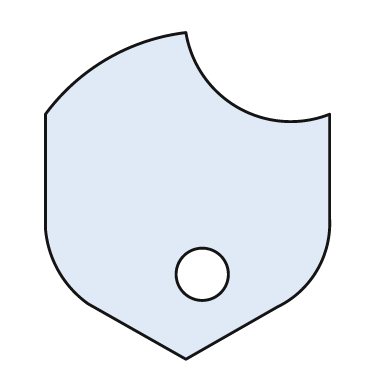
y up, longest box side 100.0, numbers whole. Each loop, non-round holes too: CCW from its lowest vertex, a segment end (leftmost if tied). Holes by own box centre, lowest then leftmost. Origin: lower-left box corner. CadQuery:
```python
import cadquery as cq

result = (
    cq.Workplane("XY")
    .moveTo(43.0, 0.0)
    .lineTo(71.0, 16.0)
    .threePointArc((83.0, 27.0), (87.0, 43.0))
    .lineTo(87.0, 75.0)
    .threePointArc((59.0, 77.0), (43.0, 100.0))
    .threePointArc((19.0, 92.0), (0.0, 75.0))
    .lineTo(0.0, 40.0)
    .threePointArc((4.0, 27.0), (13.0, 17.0))
    .close()
    .moveTo(48.0, 26.0)
    .circle(8.0)
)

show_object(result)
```